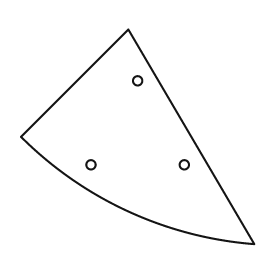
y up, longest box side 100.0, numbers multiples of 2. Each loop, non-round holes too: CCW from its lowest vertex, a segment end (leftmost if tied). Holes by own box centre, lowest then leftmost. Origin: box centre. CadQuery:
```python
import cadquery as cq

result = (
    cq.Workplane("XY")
    .moveTo(50.0, -46.0)
    .lineTo(-4.0, 46.0)
    .lineTo(-50.0, 0.0)
    .threePointArc((-4.0, -32.0), (50.0, -46.0))
    .close()
    .moveTo(-20.0, -12.0)
    .circle(2.0)
    .moveTo(20.0, -12.0)
    .circle(2.0)
    .moveTo(0.0, 24.0)
    .circle(2.0)
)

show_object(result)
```